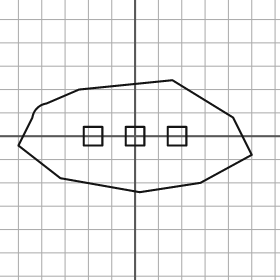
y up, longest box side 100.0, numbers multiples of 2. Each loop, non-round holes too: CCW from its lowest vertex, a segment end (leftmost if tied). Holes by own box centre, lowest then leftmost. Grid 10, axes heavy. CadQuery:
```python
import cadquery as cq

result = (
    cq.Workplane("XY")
    .moveTo(2.0, -24.0)
    .lineTo(28.0, -20.0)
    .lineTo(50.0, -8.0)
    .lineTo(42.0, 8.0)
    .lineTo(16.0, 24.0)
    .lineTo(-24.0, 20.0)
    .lineTo(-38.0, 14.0)
    .threePointArc((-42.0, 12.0), (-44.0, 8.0))
    .lineTo(-50.0, -4.0)
    .lineTo(-32.0, -18.0)
    .close()
    .moveTo(-22.0, -4.0)
    .lineTo(-14.0, -4.0)
    .lineTo(-14.0, 4.0)
    .lineTo(-22.0, 4.0)
    .close()
    .moveTo(-4.0, -4.0)
    .lineTo(4.0, -4.0)
    .lineTo(4.0, 4.0)
    .lineTo(-4.0, 4.0)
    .close()
    .moveTo(14.0, -4.0)
    .lineTo(22.0, -4.0)
    .lineTo(22.0, 4.0)
    .lineTo(14.0, 4.0)
    .close()
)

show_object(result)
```